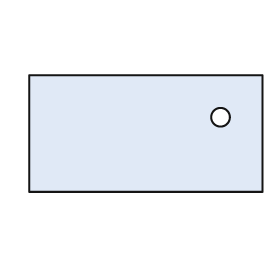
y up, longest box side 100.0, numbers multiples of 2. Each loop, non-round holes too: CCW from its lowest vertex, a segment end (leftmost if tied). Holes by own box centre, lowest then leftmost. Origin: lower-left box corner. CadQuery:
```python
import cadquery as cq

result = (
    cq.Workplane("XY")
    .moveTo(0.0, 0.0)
    .lineTo(100.0, 0.0)
    .lineTo(100.0, 50.0)
    .lineTo(0.0, 50.0)
    .close()
    .moveTo(82.0, 32.0)
    .circle(4.0)
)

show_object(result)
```